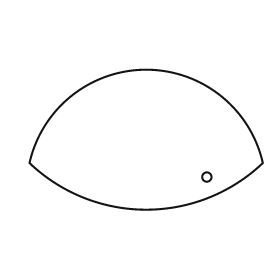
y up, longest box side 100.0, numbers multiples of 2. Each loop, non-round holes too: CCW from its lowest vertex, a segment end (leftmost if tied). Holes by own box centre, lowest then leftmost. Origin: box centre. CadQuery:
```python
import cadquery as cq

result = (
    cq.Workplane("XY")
    .moveTo(-50.0, -10.0)
    .threePointArc((0.0, -30.0), (50.0, -10.0))
    .threePointArc((0.0, 30.0), (-50.0, -10.0))
    .close()
    .moveTo(26.0, -16.0)
    .circle(2.0)
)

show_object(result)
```